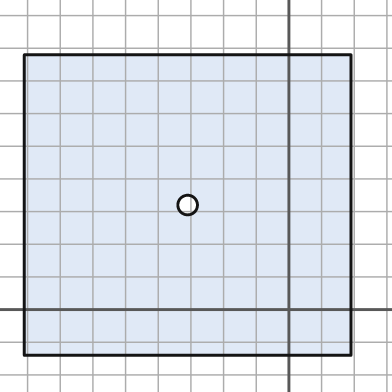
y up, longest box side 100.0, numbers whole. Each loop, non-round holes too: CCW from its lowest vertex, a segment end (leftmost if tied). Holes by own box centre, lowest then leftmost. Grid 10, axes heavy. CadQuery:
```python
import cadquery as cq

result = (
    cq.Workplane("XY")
    .moveTo(-81.0, -14.0)
    .lineTo(19.0, -14.0)
    .lineTo(19.0, 78.0)
    .lineTo(-81.0, 78.0)
    .close()
    .moveTo(-31.0, 32.0)
    .circle(3.0)
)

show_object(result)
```